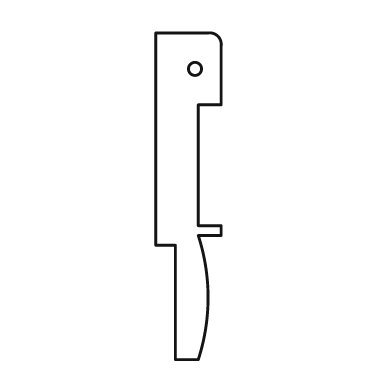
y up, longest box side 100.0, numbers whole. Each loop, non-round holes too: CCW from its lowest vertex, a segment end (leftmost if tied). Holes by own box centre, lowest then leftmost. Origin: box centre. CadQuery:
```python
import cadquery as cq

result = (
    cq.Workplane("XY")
    .moveTo(-4.0, -50.0)
    .lineTo(3.0, -50.0)
    .threePointArc((6.0, -31.0), (3.0, -12.0))
    .lineTo(10.0, -12.0)
    .lineTo(10.0, -9.0)
    .lineTo(3.0, -9.0)
    .lineTo(3.0, 28.0)
    .lineTo(10.0, 28.0)
    .lineTo(10.0, 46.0)
    .threePointArc((9.0, 49.0), (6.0, 50.0))
    .lineTo(-10.0, 50.0)
    .lineTo(-10.0, -15.0)
    .lineTo(-4.0, -15.0)
    .close()
    .moveTo(2.0, 39.0)
    .circle(2.0)
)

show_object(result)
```